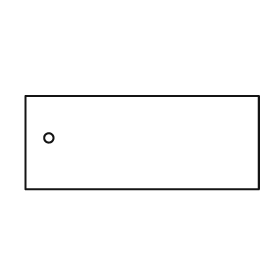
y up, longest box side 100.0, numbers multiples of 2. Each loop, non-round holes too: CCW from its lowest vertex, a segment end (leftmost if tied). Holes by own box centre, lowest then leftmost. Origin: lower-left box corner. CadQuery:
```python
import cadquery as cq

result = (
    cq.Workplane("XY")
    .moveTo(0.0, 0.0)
    .lineTo(100.0, 0.0)
    .lineTo(100.0, 40.0)
    .lineTo(0.0, 40.0)
    .close()
    .moveTo(10.0, 22.0)
    .circle(2.0)
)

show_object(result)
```